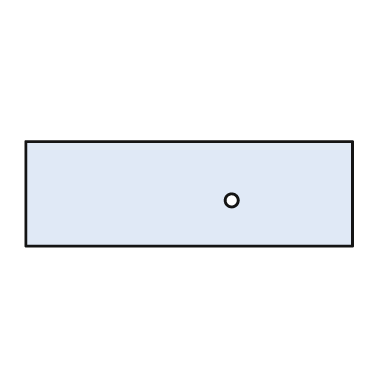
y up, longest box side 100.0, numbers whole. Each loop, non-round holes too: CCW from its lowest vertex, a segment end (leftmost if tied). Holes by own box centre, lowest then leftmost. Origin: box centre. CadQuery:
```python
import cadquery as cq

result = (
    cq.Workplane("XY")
    .moveTo(-50.0, -16.0)
    .lineTo(50.0, -16.0)
    .lineTo(50.0, 16.0)
    .lineTo(-50.0, 16.0)
    .close()
    .moveTo(13.0, -2.0)
    .circle(2.0)
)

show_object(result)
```